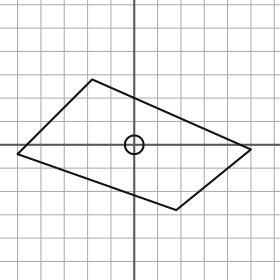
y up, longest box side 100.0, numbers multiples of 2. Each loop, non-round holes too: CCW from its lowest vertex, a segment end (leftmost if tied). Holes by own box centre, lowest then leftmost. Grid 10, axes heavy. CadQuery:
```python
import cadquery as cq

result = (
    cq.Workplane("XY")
    .moveTo(18.0, -28.0)
    .lineTo(50.0, -2.0)
    .lineTo(-18.0, 28.0)
    .lineTo(-50.0, -4.0)
    .close()
    .moveTo(0.0, 0.0)
    .circle(4.0)
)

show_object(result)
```